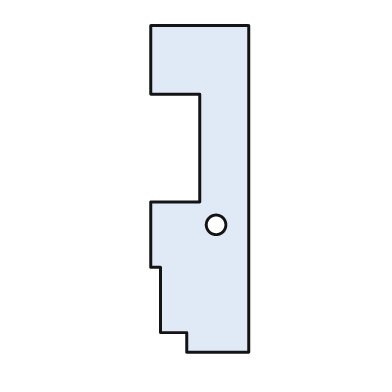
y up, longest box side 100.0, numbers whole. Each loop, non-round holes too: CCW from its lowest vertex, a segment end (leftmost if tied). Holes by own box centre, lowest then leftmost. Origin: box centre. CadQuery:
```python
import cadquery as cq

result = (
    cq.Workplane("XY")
    .moveTo(-4.0, -50.0)
    .lineTo(15.0, -50.0)
    .lineTo(15.0, 50.0)
    .lineTo(-15.0, 50.0)
    .lineTo(-15.0, 29.0)
    .lineTo(0.0, 29.0)
    .lineTo(0.0, -4.0)
    .lineTo(-15.0, -4.0)
    .lineTo(-15.0, -24.0)
    .lineTo(-12.0, -24.0)
    .lineTo(-12.0, -44.0)
    .lineTo(-4.0, -44.0)
    .close()
    .moveTo(5.0, -11.0)
    .circle(3.0)
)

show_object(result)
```